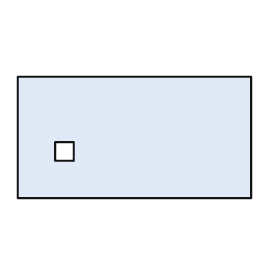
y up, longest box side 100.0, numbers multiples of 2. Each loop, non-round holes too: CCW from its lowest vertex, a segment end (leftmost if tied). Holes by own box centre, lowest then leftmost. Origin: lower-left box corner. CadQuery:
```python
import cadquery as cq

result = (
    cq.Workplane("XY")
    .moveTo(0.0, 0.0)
    .lineTo(100.0, 0.0)
    .lineTo(100.0, 52.0)
    .lineTo(0.0, 52.0)
    .close()
    .moveTo(16.0, 16.0)
    .lineTo(24.0, 16.0)
    .lineTo(24.0, 24.0)
    .lineTo(16.0, 24.0)
    .close()
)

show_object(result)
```